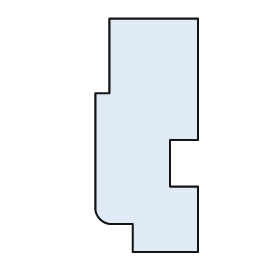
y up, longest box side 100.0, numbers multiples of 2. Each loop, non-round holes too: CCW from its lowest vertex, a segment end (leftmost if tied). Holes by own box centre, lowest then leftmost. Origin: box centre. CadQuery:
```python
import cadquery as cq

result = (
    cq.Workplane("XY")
    .moveTo(-6.0, -50.0)
    .lineTo(22.0, -50.0)
    .lineTo(22.0, -22.0)
    .lineTo(10.0, -22.0)
    .lineTo(10.0, -2.0)
    .lineTo(22.0, -2.0)
    .lineTo(22.0, 50.0)
    .lineTo(-16.0, 50.0)
    .lineTo(-16.0, 18.0)
    .lineTo(-22.0, 18.0)
    .lineTo(-22.0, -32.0)
    .threePointArc((-20.0, -36.0), (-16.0, -38.0))
    .lineTo(-6.0, -38.0)
    .close()
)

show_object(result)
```